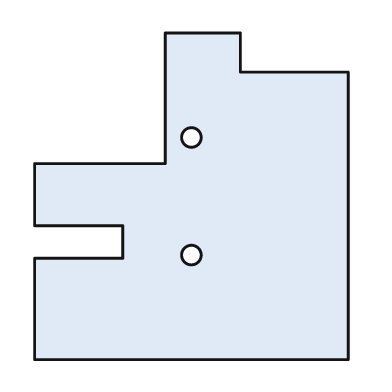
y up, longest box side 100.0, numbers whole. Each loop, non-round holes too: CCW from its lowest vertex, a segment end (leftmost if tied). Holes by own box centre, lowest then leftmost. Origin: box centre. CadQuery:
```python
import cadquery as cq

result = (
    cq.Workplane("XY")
    .moveTo(-48.0, -50.0)
    .lineTo(48.0, -50.0)
    .lineTo(48.0, 38.0)
    .lineTo(15.0, 38.0)
    .lineTo(15.0, 50.0)
    .lineTo(-8.0, 50.0)
    .lineTo(-8.0, 10.0)
    .lineTo(-48.0, 10.0)
    .lineTo(-48.0, -9.0)
    .lineTo(-21.0, -9.0)
    .lineTo(-21.0, -19.0)
    .lineTo(-48.0, -19.0)
    .close()
    .moveTo(0.0, -18.0)
    .circle(3.0)
    .moveTo(0.0, 18.0)
    .circle(3.0)
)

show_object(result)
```